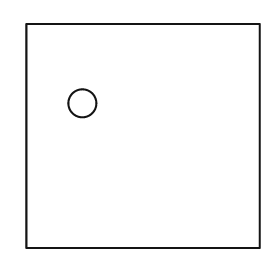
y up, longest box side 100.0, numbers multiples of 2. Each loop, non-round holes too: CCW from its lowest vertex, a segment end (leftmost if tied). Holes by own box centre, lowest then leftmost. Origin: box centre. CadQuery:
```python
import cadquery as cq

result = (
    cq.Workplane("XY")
    .moveTo(-50.0, -48.0)
    .lineTo(50.0, -48.0)
    .lineTo(50.0, 48.0)
    .lineTo(-50.0, 48.0)
    .close()
    .moveTo(-26.0, 14.0)
    .circle(6.0)
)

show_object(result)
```